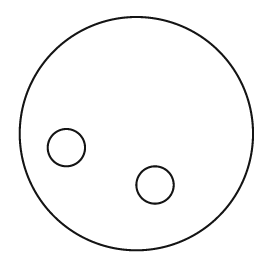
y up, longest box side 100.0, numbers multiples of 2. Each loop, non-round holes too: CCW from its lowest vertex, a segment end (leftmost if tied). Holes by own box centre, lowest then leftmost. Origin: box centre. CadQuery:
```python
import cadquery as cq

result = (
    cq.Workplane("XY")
    .moveTo(0.0, 0.0)
    .circle(50.0)
    .moveTo(8.0, -22.0)
    .circle(8.0)
    .moveTo(-30.0, -6.0)
    .circle(8.0)
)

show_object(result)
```